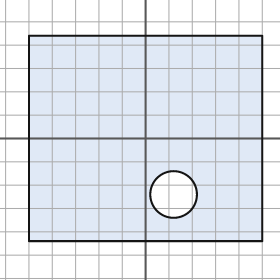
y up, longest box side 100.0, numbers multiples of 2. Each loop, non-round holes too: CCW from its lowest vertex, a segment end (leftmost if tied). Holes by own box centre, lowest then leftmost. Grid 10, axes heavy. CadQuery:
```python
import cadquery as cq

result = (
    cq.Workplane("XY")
    .moveTo(-50.0, -44.0)
    .lineTo(50.0, -44.0)
    .lineTo(50.0, 44.0)
    .lineTo(-50.0, 44.0)
    .close()
    .moveTo(12.0, -24.0)
    .circle(10.0)
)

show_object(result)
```